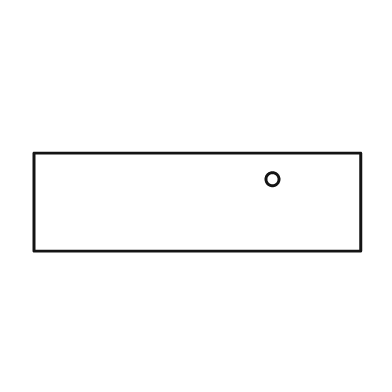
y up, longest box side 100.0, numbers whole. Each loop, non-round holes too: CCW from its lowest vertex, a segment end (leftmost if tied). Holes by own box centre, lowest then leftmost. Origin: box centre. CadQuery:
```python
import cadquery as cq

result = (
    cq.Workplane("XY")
    .moveTo(-50.0, -15.0)
    .lineTo(50.0, -15.0)
    .lineTo(50.0, 15.0)
    .lineTo(-50.0, 15.0)
    .close()
    .moveTo(23.0, 7.0)
    .circle(2.0)
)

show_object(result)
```